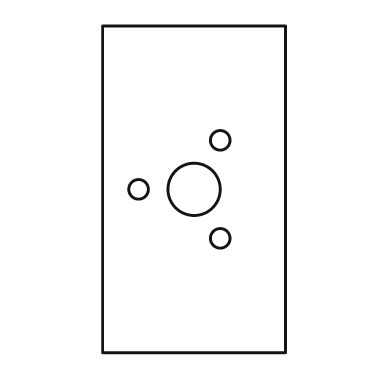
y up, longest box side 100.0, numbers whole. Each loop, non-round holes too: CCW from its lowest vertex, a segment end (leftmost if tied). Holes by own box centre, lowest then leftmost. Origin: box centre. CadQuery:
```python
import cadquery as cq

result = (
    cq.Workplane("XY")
    .moveTo(-28.0, -50.0)
    .lineTo(28.0, -50.0)
    .lineTo(28.0, 50.0)
    .lineTo(-28.0, 50.0)
    .close()
    .moveTo(8.0, -15.0)
    .circle(3.0)
    .moveTo(-17.0, 0.0)
    .circle(3.0)
    .moveTo(0.0, 0.0)
    .circle(8.0)
    .moveTo(8.0, 15.0)
    .circle(3.0)
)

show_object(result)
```